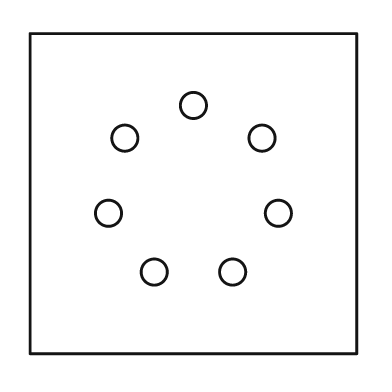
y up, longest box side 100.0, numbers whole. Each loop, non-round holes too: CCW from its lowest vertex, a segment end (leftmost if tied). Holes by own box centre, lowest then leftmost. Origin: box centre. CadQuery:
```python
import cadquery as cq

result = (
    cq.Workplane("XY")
    .moveTo(-50.0, -49.0)
    .lineTo(50.0, -49.0)
    .lineTo(50.0, 49.0)
    .lineTo(-50.0, 49.0)
    .close()
    .moveTo(-12.0, -24.0)
    .circle(4.0)
    .moveTo(12.0, -24.0)
    .circle(4.0)
    .moveTo(-26.0, -6.0)
    .circle(4.0)
    .moveTo(26.0, -6.0)
    .circle(4.0)
    .moveTo(-21.0, 17.0)
    .circle(4.0)
    .moveTo(21.0, 17.0)
    .circle(4.0)
    .moveTo(0.0, 27.0)
    .circle(4.0)
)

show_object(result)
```